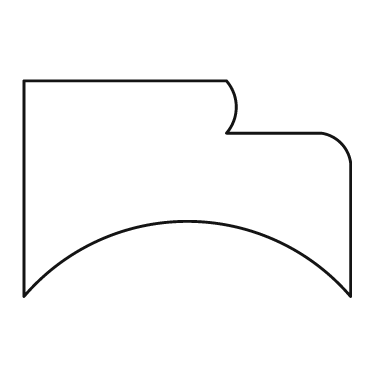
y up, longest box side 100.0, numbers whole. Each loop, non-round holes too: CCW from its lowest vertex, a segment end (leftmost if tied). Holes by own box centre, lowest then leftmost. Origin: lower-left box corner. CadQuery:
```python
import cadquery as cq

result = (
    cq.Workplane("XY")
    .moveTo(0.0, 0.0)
    .threePointArc((50.0, 23.0), (100.0, 0.0))
    .lineTo(100.0, 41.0)
    .threePointArc((97.0, 47.0), (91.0, 50.0))
    .lineTo(62.0, 50.0)
    .threePointArc((65.0, 58.0), (62.0, 66.0))
    .lineTo(0.0, 66.0)
    .close()
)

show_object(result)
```